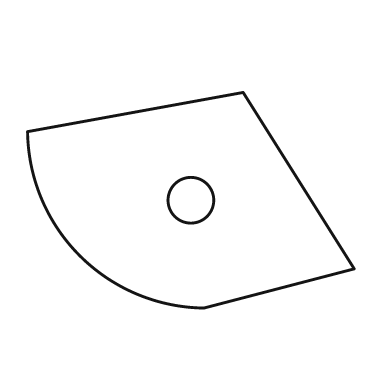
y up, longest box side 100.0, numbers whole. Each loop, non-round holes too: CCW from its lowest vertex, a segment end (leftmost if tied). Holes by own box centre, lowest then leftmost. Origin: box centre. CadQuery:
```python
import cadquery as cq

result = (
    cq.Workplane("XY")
    .moveTo(4.0, -33.0)
    .lineTo(50.0, -21.0)
    .lineTo(16.0, 33.0)
    .lineTo(-50.0, 21.0)
    .threePointArc((-34.0, -17.0), (4.0, -33.0))
    .close()
    .moveTo(0.0, 0.0)
    .circle(7.0)
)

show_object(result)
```